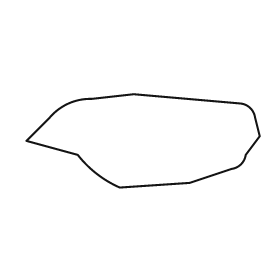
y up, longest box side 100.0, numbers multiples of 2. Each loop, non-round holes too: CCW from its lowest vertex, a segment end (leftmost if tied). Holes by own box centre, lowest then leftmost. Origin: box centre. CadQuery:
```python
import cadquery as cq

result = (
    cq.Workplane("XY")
    .moveTo(-10.0, -20.0)
    .lineTo(20.0, -18.0)
    .lineTo(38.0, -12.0)
    .threePointArc((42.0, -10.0), (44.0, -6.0))
    .lineTo(50.0, 2.0)
    .lineTo(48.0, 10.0)
    .threePointArc((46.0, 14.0), (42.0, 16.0))
    .lineTo(-4.0, 20.0)
    .lineTo(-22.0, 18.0)
    .threePointArc((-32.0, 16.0), (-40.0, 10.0))
    .lineTo(-50.0, 0.0)
    .lineTo(-28.0, -6.0)
    .threePointArc((-20.0, -14.0), (-10.0, -20.0))
    .close()
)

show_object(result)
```